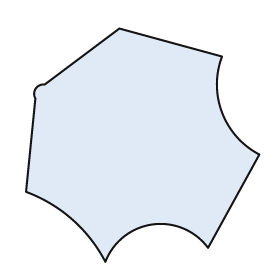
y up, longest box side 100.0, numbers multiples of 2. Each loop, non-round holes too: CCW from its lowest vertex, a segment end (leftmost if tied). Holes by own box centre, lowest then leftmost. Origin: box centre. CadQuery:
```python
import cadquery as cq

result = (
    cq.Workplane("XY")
    .moveTo(-16.0, -50.0)
    .threePointArc((4.0, -34.0), (28.0, -44.0))
    .lineTo(50.0, -4.0)
    .threePointArc((34.0, 14.0), (34.0, 38.0))
    .lineTo(-10.0, 50.0)
    .lineTo(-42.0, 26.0)
    .threePointArc((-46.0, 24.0), (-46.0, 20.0))
    .lineTo(-50.0, -20.0)
    .threePointArc((-30.0, -32.0), (-16.0, -50.0))
    .close()
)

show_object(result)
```